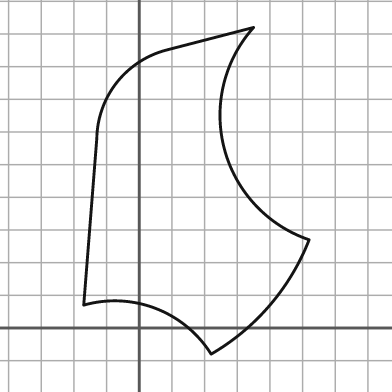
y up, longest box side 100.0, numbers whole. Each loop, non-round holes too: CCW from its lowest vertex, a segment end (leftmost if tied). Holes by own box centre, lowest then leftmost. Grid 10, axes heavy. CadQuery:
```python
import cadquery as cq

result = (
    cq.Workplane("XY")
    .moveTo(22.0, -8.0)
    .threePointArc((40.0, 7.0), (52.0, 27.0))
    .threePointArc((26.0, 55.0), (35.0, 92.0))
    .lineTo(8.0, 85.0)
    .threePointArc((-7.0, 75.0), (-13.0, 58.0))
    .lineTo(-17.0, 7.0)
    .threePointArc((5.0, 6.0), (22.0, -8.0))
    .close()
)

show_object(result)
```